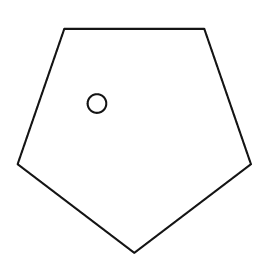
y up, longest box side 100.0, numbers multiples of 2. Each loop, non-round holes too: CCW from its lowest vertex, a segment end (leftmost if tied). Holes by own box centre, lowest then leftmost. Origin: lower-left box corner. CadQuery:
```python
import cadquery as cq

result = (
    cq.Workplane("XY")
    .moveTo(50.0, 0.0)
    .lineTo(100.0, 38.0)
    .lineTo(80.0, 96.0)
    .lineTo(20.0, 96.0)
    .lineTo(0.0, 38.0)
    .close()
    .moveTo(34.0, 64.0)
    .circle(4.0)
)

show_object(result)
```